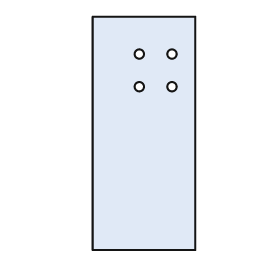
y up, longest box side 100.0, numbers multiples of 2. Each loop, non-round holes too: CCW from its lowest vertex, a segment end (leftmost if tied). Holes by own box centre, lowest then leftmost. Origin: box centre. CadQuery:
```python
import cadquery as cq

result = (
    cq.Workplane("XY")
    .moveTo(-22.0, -50.0)
    .lineTo(22.0, -50.0)
    .lineTo(22.0, 50.0)
    .lineTo(-22.0, 50.0)
    .close()
    .moveTo(-2.0, 20.0)
    .circle(2.0)
    .moveTo(12.0, 20.0)
    .circle(2.0)
    .moveTo(-2.0, 34.0)
    .circle(2.0)
    .moveTo(12.0, 34.0)
    .circle(2.0)
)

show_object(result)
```